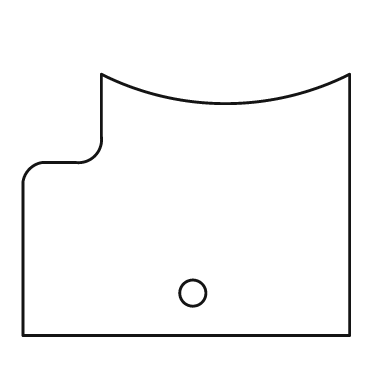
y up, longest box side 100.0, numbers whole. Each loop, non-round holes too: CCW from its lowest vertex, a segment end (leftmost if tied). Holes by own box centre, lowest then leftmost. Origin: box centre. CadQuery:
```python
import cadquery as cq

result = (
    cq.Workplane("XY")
    .moveTo(-50.0, -40.0)
    .lineTo(50.0, -40.0)
    .lineTo(50.0, 40.0)
    .threePointArc((12.0, 31.0), (-26.0, 40.0))
    .lineTo(-26.0, 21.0)
    .threePointArc((-28.0, 15.0), (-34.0, 13.0))
    .lineTo(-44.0, 13.0)
    .threePointArc((-48.0, 11.0), (-50.0, 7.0))
    .close()
    .moveTo(2.0, -27.0)
    .circle(4.0)
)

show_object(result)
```